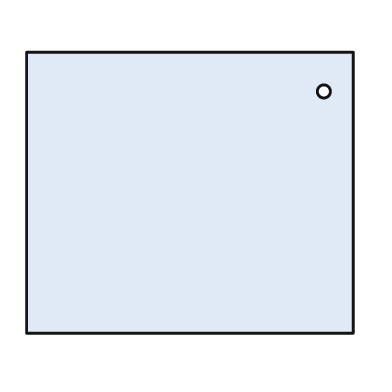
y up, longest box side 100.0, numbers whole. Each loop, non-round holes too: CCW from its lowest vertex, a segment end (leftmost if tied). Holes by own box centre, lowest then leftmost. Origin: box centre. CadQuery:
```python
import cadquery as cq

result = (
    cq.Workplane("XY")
    .moveTo(-50.0, -43.0)
    .lineTo(50.0, -43.0)
    .lineTo(50.0, 43.0)
    .lineTo(-50.0, 43.0)
    .close()
    .moveTo(41.0, 31.0)
    .circle(2.0)
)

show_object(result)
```